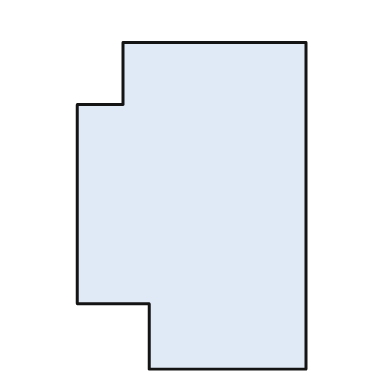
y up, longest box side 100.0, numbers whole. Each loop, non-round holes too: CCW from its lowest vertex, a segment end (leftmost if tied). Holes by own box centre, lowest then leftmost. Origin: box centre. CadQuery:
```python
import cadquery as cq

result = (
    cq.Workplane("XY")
    .moveTo(-13.0, -50.0)
    .lineTo(35.0, -50.0)
    .lineTo(35.0, 50.0)
    .lineTo(-21.0, 50.0)
    .lineTo(-21.0, 31.0)
    .lineTo(-35.0, 31.0)
    .lineTo(-35.0, -30.0)
    .lineTo(-13.0, -30.0)
    .close()
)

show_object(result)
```